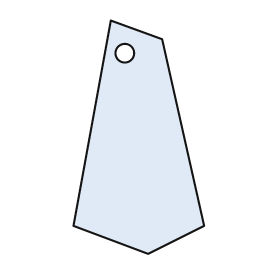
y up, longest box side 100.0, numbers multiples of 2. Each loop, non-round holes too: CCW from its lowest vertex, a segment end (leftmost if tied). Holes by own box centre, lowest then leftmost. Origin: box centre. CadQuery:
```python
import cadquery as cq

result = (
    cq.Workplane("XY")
    .moveTo(4.0, -50.0)
    .lineTo(28.0, -38.0)
    .lineTo(10.0, 42.0)
    .lineTo(-12.0, 50.0)
    .lineTo(-28.0, -38.0)
    .close()
    .moveTo(-6.0, 36.0)
    .circle(4.0)
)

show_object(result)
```